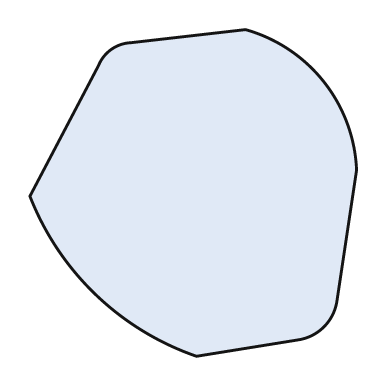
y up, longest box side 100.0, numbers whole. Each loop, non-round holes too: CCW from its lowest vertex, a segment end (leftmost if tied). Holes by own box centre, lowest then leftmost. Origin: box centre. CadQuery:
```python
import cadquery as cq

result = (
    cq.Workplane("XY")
    .moveTo(1.0, -50.0)
    .lineTo(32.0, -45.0)
    .threePointArc((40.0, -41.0), (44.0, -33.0))
    .lineTo(50.0, 7.0)
    .threePointArc((40.0, 34.0), (16.0, 50.0))
    .lineTo(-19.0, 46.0)
    .threePointArc((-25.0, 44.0), (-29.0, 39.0))
    .lineTo(-50.0, -1.0)
    .threePointArc((-30.0, -31.0), (1.0, -50.0))
    .close()
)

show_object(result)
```